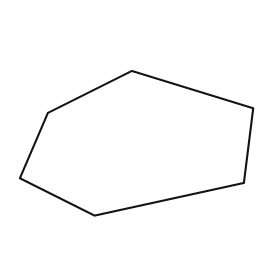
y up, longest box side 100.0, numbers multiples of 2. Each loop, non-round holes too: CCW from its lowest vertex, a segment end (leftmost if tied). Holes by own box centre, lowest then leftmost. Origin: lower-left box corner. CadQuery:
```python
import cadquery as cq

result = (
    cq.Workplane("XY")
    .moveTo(32.0, 0.0)
    .lineTo(96.0, 14.0)
    .lineTo(100.0, 46.0)
    .lineTo(48.0, 62.0)
    .lineTo(12.0, 44.0)
    .lineTo(0.0, 16.0)
    .close()
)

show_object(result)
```